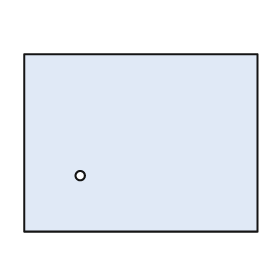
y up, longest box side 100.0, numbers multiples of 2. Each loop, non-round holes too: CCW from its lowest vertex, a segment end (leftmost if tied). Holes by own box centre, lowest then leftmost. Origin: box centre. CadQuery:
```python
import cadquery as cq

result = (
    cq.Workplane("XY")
    .moveTo(-50.0, -38.0)
    .lineTo(50.0, -38.0)
    .lineTo(50.0, 38.0)
    .lineTo(-50.0, 38.0)
    .close()
    .moveTo(-26.0, -14.0)
    .circle(2.0)
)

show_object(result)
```